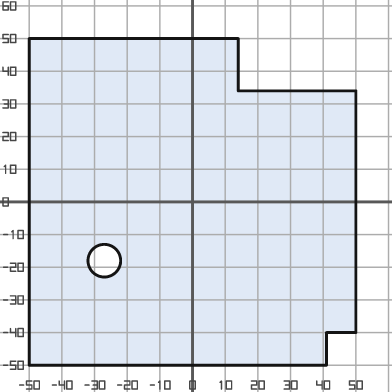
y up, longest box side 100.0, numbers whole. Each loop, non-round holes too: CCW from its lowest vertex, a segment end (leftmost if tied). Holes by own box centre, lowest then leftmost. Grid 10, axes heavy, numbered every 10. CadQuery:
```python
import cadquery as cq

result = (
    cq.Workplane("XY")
    .moveTo(-50.0, -50.0)
    .lineTo(41.0, -50.0)
    .lineTo(41.0, -40.0)
    .lineTo(50.0, -40.0)
    .lineTo(50.0, 34.0)
    .lineTo(14.0, 34.0)
    .lineTo(14.0, 50.0)
    .lineTo(-50.0, 50.0)
    .close()
    .moveTo(-27.0, -18.0)
    .circle(5.0)
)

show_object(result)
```